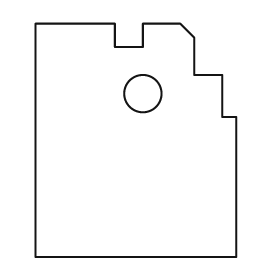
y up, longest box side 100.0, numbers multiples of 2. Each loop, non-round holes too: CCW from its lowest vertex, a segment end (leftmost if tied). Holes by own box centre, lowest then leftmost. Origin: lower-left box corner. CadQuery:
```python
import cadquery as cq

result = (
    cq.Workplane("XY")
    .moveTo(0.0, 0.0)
    .lineTo(86.0, 0.0)
    .lineTo(86.0, 60.0)
    .lineTo(80.0, 60.0)
    .lineTo(80.0, 78.0)
    .lineTo(68.0, 78.0)
    .lineTo(68.0, 94.0)
    .lineTo(62.0, 100.0)
    .lineTo(46.0, 100.0)
    .lineTo(46.0, 90.0)
    .lineTo(34.0, 90.0)
    .lineTo(34.0, 100.0)
    .lineTo(0.0, 100.0)
    .close()
    .moveTo(46.0, 70.0)
    .circle(8.0)
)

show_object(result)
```